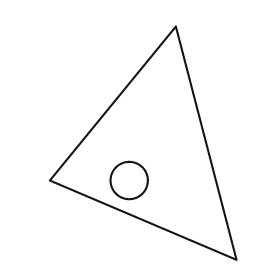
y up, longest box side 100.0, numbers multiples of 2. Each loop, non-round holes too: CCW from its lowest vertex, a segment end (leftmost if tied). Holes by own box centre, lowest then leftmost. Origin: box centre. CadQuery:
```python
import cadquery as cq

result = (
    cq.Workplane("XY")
    .moveTo(40.0, -50.0)
    .lineTo(14.0, 50.0)
    .lineTo(-40.0, -16.0)
    .close()
    .moveTo(-6.0, -16.0)
    .circle(8.0)
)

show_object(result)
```